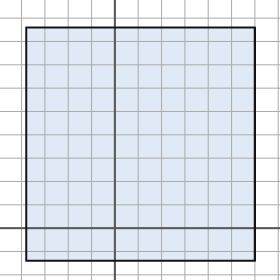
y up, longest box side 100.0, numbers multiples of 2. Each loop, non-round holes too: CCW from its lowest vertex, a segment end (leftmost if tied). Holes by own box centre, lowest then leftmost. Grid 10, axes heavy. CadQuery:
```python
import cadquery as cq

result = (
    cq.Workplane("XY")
    .moveTo(-38.0, -14.0)
    .lineTo(60.0, -14.0)
    .lineTo(60.0, 86.0)
    .lineTo(-38.0, 86.0)
    .close()
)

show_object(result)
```